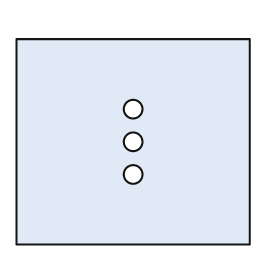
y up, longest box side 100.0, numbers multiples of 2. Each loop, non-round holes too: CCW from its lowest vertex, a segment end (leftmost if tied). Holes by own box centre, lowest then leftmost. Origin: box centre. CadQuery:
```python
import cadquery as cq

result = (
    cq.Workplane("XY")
    .moveTo(-50.0, -44.0)
    .lineTo(50.0, -44.0)
    .lineTo(50.0, 44.0)
    .lineTo(-50.0, 44.0)
    .close()
    .moveTo(0.0, -14.0)
    .circle(4.0)
    .moveTo(0.0, 0.0)
    .circle(4.0)
    .moveTo(0.0, 14.0)
    .circle(4.0)
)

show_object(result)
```